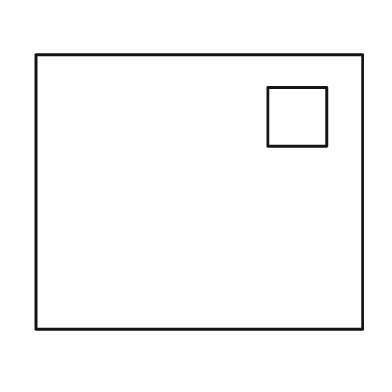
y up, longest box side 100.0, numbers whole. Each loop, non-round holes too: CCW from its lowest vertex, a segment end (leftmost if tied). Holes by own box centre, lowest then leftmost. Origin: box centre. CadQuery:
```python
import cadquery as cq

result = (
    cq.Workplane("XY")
    .moveTo(-50.0, -42.0)
    .lineTo(50.0, -42.0)
    .lineTo(50.0, 42.0)
    .lineTo(-50.0, 42.0)
    .close()
    .moveTo(21.0, 14.0)
    .lineTo(39.0, 14.0)
    .lineTo(39.0, 32.0)
    .lineTo(21.0, 32.0)
    .close()
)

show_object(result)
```